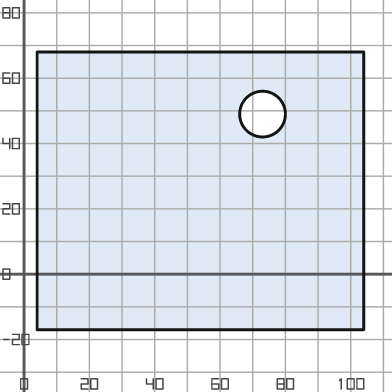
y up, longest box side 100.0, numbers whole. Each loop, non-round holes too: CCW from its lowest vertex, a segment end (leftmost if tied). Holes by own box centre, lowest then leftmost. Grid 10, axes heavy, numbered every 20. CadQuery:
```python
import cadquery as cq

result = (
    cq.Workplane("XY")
    .moveTo(4.0, -17.0)
    .lineTo(104.0, -17.0)
    .lineTo(104.0, 68.0)
    .lineTo(4.0, 68.0)
    .close()
    .moveTo(73.0, 49.0)
    .circle(7.0)
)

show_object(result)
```